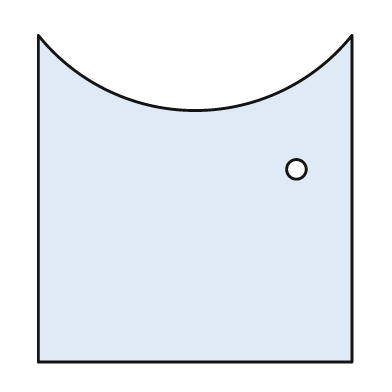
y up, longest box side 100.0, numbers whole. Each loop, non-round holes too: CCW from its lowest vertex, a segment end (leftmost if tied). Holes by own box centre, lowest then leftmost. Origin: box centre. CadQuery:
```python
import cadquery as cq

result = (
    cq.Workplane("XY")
    .moveTo(-48.0, -50.0)
    .lineTo(48.0, -50.0)
    .lineTo(48.0, 50.0)
    .threePointArc((0.0, 27.0), (-48.0, 50.0))
    .close()
    .moveTo(31.0, 9.0)
    .circle(3.0)
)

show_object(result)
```